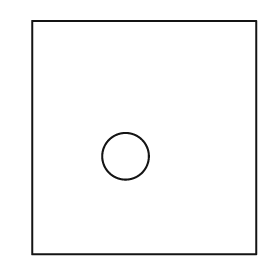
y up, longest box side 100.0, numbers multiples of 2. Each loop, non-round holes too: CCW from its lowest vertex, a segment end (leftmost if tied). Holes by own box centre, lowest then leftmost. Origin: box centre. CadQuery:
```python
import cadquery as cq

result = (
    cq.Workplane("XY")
    .moveTo(-48.0, -50.0)
    .lineTo(48.0, -50.0)
    .lineTo(48.0, 50.0)
    .lineTo(-48.0, 50.0)
    .close()
    .moveTo(-8.0, -8.0)
    .circle(10.0)
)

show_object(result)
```